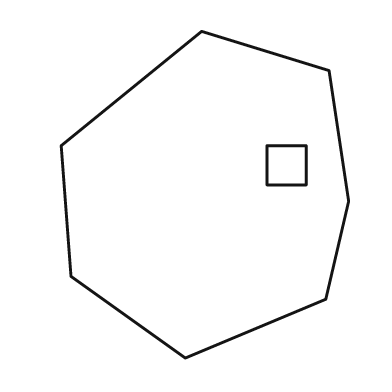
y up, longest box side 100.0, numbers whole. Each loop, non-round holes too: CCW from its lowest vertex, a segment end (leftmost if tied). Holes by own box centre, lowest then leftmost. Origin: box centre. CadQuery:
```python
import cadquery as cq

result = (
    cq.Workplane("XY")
    .moveTo(-6.0, -50.0)
    .lineTo(37.0, -32.0)
    .lineTo(44.0, -2.0)
    .lineTo(38.0, 38.0)
    .lineTo(-1.0, 50.0)
    .lineTo(-44.0, 15.0)
    .lineTo(-41.0, -25.0)
    .close()
    .moveTo(19.0, 3.0)
    .lineTo(31.0, 3.0)
    .lineTo(31.0, 15.0)
    .lineTo(19.0, 15.0)
    .close()
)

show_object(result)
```